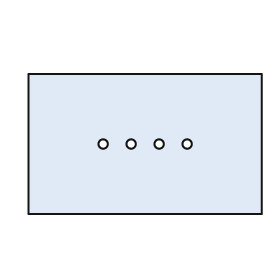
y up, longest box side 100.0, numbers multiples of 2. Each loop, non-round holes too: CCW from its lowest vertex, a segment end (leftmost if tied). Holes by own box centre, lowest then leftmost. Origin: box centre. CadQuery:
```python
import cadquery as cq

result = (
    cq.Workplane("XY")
    .moveTo(-50.0, -30.0)
    .lineTo(50.0, -30.0)
    .lineTo(50.0, 30.0)
    .lineTo(-50.0, 30.0)
    .close()
    .moveTo(-18.0, 0.0)
    .circle(2.0)
    .moveTo(-6.0, 0.0)
    .circle(2.0)
    .moveTo(6.0, 0.0)
    .circle(2.0)
    .moveTo(18.0, 0.0)
    .circle(2.0)
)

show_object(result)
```